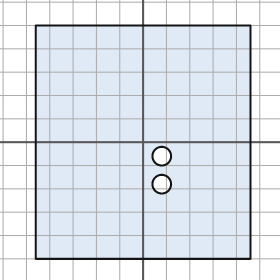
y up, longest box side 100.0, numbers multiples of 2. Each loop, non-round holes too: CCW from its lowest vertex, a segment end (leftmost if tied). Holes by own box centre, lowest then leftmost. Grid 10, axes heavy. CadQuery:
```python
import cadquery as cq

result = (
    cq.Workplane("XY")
    .moveTo(-46.0, -50.0)
    .lineTo(46.0, -50.0)
    .lineTo(46.0, 50.0)
    .lineTo(-46.0, 50.0)
    .close()
    .moveTo(8.0, -18.0)
    .circle(4.0)
    .moveTo(8.0, -6.0)
    .circle(4.0)
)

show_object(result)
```